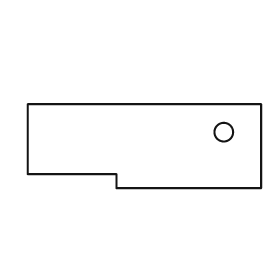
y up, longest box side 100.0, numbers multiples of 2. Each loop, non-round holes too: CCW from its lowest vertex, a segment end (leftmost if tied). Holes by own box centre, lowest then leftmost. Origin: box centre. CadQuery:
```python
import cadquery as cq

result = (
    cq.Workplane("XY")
    .moveTo(-12.0, -18.0)
    .lineTo(50.0, -18.0)
    .lineTo(50.0, 18.0)
    .lineTo(-50.0, 18.0)
    .lineTo(-50.0, -12.0)
    .lineTo(-12.0, -12.0)
    .close()
    .moveTo(34.0, 6.0)
    .circle(4.0)
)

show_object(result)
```